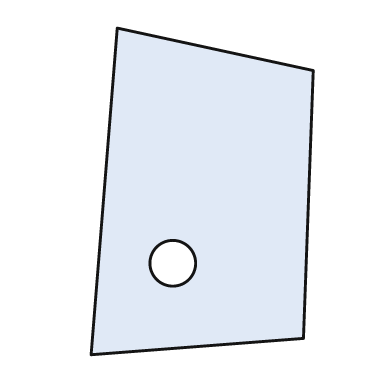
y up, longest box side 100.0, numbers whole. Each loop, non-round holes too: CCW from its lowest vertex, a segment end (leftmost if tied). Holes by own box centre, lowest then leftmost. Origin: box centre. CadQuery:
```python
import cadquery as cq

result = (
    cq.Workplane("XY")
    .moveTo(-34.0, -50.0)
    .lineTo(31.0, -45.0)
    .lineTo(34.0, 37.0)
    .lineTo(-26.0, 50.0)
    .close()
    .moveTo(-9.0, -22.0)
    .circle(7.0)
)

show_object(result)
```